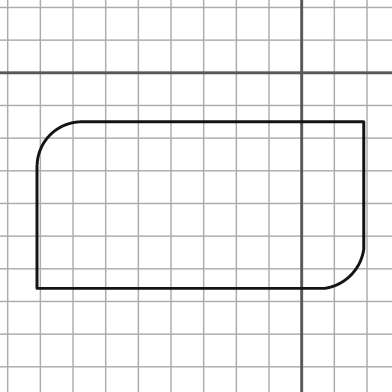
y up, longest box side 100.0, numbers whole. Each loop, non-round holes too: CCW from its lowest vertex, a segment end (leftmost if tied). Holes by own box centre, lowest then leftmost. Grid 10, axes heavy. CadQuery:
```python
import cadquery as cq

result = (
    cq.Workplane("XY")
    .moveTo(-81.0, -66.0)
    .lineTo(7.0, -66.0)
    .threePointArc((15.0, -62.0), (19.0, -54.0))
    .lineTo(19.0, -15.0)
    .lineTo(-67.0, -15.0)
    .threePointArc((-77.0, -19.0), (-81.0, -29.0))
    .close()
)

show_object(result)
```